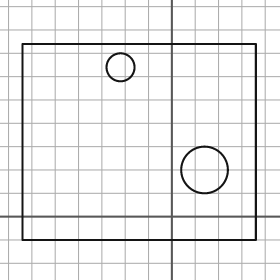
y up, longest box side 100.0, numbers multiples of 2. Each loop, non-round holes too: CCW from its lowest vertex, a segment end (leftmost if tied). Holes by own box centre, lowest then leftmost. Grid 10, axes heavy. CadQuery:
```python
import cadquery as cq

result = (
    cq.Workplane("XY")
    .moveTo(-64.0, -10.0)
    .lineTo(36.0, -10.0)
    .lineTo(36.0, 74.0)
    .lineTo(-64.0, 74.0)
    .close()
    .moveTo(14.0, 20.0)
    .circle(10.0)
    .moveTo(-22.0, 64.0)
    .circle(6.0)
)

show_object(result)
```